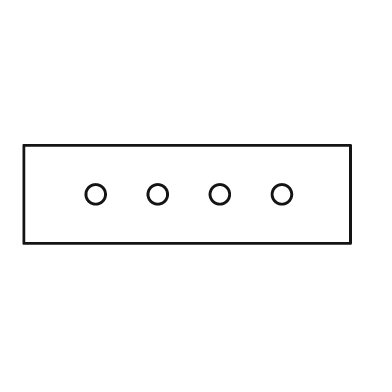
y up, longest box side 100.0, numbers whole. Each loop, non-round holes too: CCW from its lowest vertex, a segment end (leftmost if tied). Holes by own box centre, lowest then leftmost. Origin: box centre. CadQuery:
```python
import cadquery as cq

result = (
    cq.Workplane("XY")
    .moveTo(-50.0, -15.0)
    .lineTo(50.0, -15.0)
    .lineTo(50.0, 15.0)
    .lineTo(-50.0, 15.0)
    .close()
    .moveTo(-28.0, 0.0)
    .circle(3.0)
    .moveTo(-9.0, 0.0)
    .circle(3.0)
    .moveTo(10.0, 0.0)
    .circle(3.0)
    .moveTo(29.0, 0.0)
    .circle(3.0)
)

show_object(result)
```